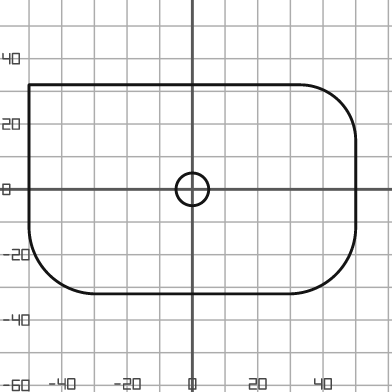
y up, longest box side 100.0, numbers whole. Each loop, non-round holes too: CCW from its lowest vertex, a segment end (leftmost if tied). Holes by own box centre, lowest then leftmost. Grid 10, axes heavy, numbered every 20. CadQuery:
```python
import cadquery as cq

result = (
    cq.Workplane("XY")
    .moveTo(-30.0, -32.0)
    .lineTo(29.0, -32.0)
    .threePointArc((44.0, -26.0), (50.0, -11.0))
    .lineTo(50.0, 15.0)
    .threePointArc((45.0, 27.0), (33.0, 32.0))
    .lineTo(-50.0, 32.0)
    .lineTo(-50.0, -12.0)
    .threePointArc((-44.0, -26.0), (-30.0, -32.0))
    .close()
    .moveTo(0.0, 0.0)
    .circle(5.0)
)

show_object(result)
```